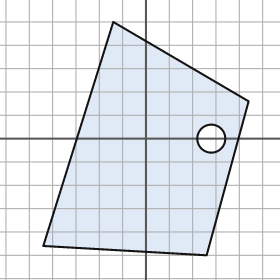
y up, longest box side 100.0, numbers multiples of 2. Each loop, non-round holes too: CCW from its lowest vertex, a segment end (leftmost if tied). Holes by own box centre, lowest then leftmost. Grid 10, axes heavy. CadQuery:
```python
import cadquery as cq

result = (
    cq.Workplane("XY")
    .moveTo(26.0, -50.0)
    .lineTo(44.0, 16.0)
    .lineTo(-14.0, 50.0)
    .lineTo(-44.0, -46.0)
    .close()
    .moveTo(28.0, 0.0)
    .circle(6.0)
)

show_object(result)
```